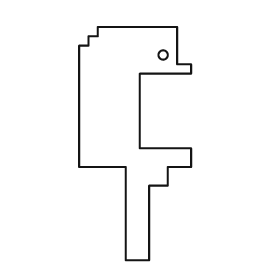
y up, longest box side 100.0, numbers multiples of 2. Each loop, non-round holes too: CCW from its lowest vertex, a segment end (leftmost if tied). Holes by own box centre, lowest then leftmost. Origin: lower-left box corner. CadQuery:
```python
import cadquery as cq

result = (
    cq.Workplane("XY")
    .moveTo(20.0, 0.0)
    .lineTo(30.0, 0.0)
    .lineTo(30.0, 32.0)
    .lineTo(38.0, 32.0)
    .lineTo(38.0, 40.0)
    .lineTo(48.0, 40.0)
    .lineTo(48.0, 48.0)
    .lineTo(26.0, 48.0)
    .lineTo(26.0, 80.0)
    .lineTo(48.0, 80.0)
    .lineTo(48.0, 84.0)
    .lineTo(42.0, 84.0)
    .lineTo(42.0, 100.0)
    .lineTo(8.0, 100.0)
    .lineTo(8.0, 96.0)
    .lineTo(4.0, 96.0)
    .lineTo(4.0, 92.0)
    .lineTo(0.0, 92.0)
    .lineTo(0.0, 40.0)
    .lineTo(20.0, 40.0)
    .close()
    .moveTo(36.0, 88.0)
    .circle(2.0)
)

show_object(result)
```